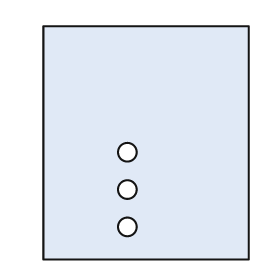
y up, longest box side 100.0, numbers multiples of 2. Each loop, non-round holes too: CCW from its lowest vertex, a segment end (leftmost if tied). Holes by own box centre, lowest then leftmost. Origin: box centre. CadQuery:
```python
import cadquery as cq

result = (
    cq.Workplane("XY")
    .moveTo(-44.0, -50.0)
    .lineTo(44.0, -50.0)
    .lineTo(44.0, 50.0)
    .lineTo(-44.0, 50.0)
    .close()
    .moveTo(-8.0, -36.0)
    .circle(4.0)
    .moveTo(-8.0, -20.0)
    .circle(4.0)
    .moveTo(-8.0, -4.0)
    .circle(4.0)
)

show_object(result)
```